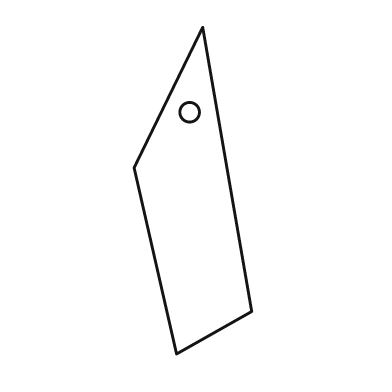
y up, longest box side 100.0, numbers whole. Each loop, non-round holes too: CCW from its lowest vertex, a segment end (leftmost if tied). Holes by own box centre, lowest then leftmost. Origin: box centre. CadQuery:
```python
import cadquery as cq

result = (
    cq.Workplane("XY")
    .moveTo(-5.0, -50.0)
    .lineTo(18.0, -37.0)
    .lineTo(3.0, 50.0)
    .lineTo(-18.0, 7.0)
    .close()
    .moveTo(-1.0, 24.0)
    .circle(3.0)
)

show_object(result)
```